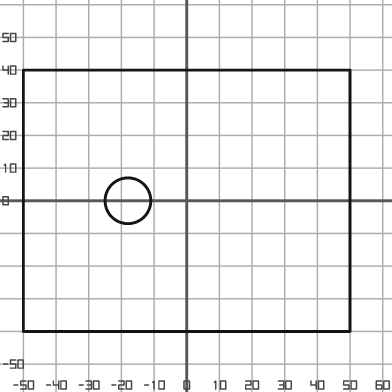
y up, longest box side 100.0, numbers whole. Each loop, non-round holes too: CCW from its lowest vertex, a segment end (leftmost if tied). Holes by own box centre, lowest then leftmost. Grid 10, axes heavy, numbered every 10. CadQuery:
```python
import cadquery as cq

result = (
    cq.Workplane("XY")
    .moveTo(-50.0, -40.0)
    .lineTo(50.0, -40.0)
    .lineTo(50.0, 40.0)
    .lineTo(-50.0, 40.0)
    .close()
    .moveTo(-18.0, 0.0)
    .circle(7.0)
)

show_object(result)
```